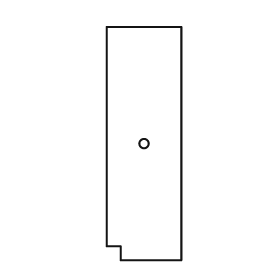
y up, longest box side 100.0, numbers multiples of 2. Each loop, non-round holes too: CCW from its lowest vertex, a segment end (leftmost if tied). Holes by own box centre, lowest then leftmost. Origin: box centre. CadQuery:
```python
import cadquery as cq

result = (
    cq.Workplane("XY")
    .moveTo(-10.0, -50.0)
    .lineTo(16.0, -50.0)
    .lineTo(16.0, 50.0)
    .lineTo(-16.0, 50.0)
    .lineTo(-16.0, -44.0)
    .lineTo(-10.0, -44.0)
    .close()
    .moveTo(0.0, 0.0)
    .circle(2.0)
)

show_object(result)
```